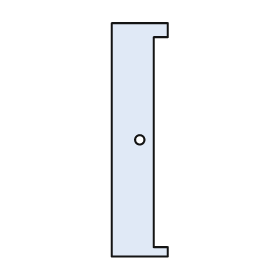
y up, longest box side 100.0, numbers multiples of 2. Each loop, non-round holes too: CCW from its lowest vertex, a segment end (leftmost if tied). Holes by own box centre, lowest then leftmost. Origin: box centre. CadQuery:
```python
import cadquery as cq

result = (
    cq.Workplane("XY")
    .moveTo(-12.0, -50.0)
    .lineTo(12.0, -50.0)
    .lineTo(12.0, -46.0)
    .lineTo(6.0, -46.0)
    .lineTo(6.0, 44.0)
    .lineTo(12.0, 44.0)
    .lineTo(12.0, 50.0)
    .lineTo(-12.0, 50.0)
    .close()
    .moveTo(0.0, 0.0)
    .circle(2.0)
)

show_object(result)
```